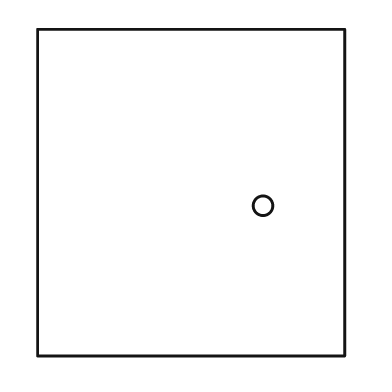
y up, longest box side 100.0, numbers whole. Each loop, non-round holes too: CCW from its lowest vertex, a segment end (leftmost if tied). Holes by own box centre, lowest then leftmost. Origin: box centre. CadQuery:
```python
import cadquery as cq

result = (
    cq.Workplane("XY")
    .moveTo(-47.0, -50.0)
    .lineTo(47.0, -50.0)
    .lineTo(47.0, 50.0)
    .lineTo(-47.0, 50.0)
    .close()
    .moveTo(22.0, -4.0)
    .circle(3.0)
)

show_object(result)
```